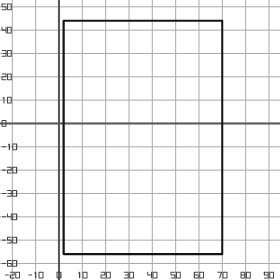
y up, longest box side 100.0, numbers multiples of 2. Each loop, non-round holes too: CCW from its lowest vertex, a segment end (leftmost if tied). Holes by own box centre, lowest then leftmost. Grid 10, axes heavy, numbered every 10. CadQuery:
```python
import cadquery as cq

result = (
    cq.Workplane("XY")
    .moveTo(2.0, -56.0)
    .lineTo(70.0, -56.0)
    .lineTo(70.0, 44.0)
    .lineTo(2.0, 44.0)
    .close()
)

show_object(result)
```